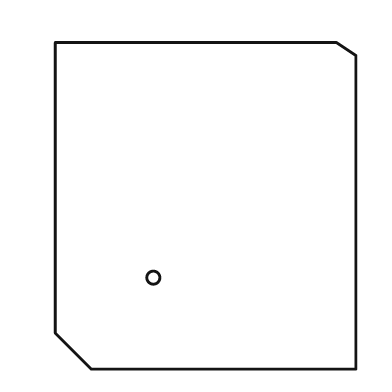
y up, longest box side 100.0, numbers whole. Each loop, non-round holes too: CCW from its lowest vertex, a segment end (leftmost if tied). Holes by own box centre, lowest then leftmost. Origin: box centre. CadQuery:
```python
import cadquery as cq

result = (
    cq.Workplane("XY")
    .moveTo(-35.0, -50.0)
    .lineTo(46.0, -50.0)
    .lineTo(46.0, 46.0)
    .lineTo(40.0, 50.0)
    .lineTo(-46.0, 50.0)
    .lineTo(-46.0, -39.0)
    .close()
    .moveTo(-16.0, -22.0)
    .circle(2.0)
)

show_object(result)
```